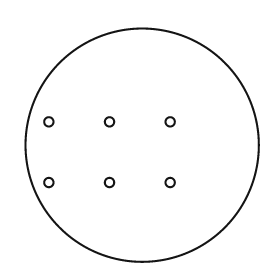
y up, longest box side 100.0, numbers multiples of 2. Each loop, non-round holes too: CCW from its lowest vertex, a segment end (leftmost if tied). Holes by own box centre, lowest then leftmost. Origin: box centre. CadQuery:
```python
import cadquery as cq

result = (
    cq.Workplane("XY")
    .moveTo(0.0, 0.0)
    .circle(50.0)
    .moveTo(-40.0, -16.0)
    .circle(2.0)
    .moveTo(-14.0, -16.0)
    .circle(2.0)
    .moveTo(12.0, -16.0)
    .circle(2.0)
    .moveTo(-40.0, 10.0)
    .circle(2.0)
    .moveTo(-14.0, 10.0)
    .circle(2.0)
    .moveTo(12.0, 10.0)
    .circle(2.0)
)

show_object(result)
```